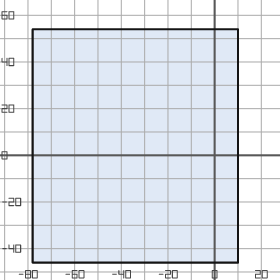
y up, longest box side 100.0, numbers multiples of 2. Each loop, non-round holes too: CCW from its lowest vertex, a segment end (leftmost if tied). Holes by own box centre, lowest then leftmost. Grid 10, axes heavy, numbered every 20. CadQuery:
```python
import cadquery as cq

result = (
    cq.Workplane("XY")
    .moveTo(-78.0, -46.0)
    .lineTo(10.0, -46.0)
    .lineTo(10.0, 54.0)
    .lineTo(-78.0, 54.0)
    .close()
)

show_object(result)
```